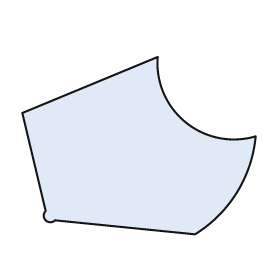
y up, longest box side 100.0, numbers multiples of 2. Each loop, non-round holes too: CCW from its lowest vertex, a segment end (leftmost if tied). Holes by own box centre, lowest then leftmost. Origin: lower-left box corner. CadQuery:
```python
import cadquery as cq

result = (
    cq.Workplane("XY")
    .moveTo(74.0, 0.0)
    .threePointArc((92.0, 18.0), (100.0, 42.0))
    .threePointArc((70.0, 48.0), (58.0, 76.0))
    .lineTo(0.0, 52.0)
    .lineTo(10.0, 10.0)
    .threePointArc((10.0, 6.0), (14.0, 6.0))
    .close()
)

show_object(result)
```